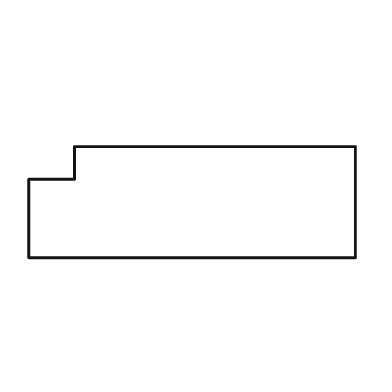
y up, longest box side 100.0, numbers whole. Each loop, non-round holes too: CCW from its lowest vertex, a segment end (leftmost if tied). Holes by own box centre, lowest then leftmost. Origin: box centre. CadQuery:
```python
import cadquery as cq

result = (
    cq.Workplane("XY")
    .moveTo(-50.0, -17.0)
    .lineTo(50.0, -17.0)
    .lineTo(50.0, 17.0)
    .lineTo(-36.0, 17.0)
    .lineTo(-36.0, 7.0)
    .lineTo(-50.0, 7.0)
    .close()
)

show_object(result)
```